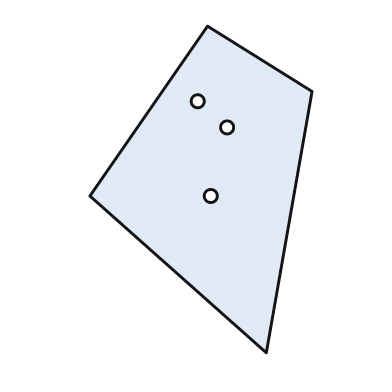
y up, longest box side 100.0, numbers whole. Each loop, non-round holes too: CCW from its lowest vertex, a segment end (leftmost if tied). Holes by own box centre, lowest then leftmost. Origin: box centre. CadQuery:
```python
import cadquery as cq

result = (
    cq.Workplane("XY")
    .moveTo(20.0, -50.0)
    .lineTo(34.0, 30.0)
    .lineTo(2.0, 50.0)
    .lineTo(-34.0, -2.0)
    .close()
    .moveTo(3.0, -2.0)
    .circle(2.0)
    .moveTo(8.0, 19.0)
    .circle(2.0)
    .moveTo(-1.0, 27.0)
    .circle(2.0)
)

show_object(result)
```